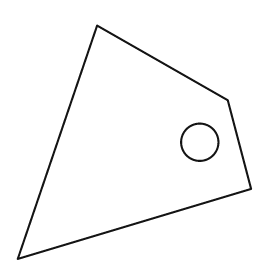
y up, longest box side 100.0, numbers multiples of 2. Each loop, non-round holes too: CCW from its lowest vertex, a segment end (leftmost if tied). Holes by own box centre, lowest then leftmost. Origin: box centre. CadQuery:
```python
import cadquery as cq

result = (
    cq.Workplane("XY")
    .moveTo(-50.0, -50.0)
    .lineTo(50.0, -20.0)
    .lineTo(40.0, 18.0)
    .lineTo(-16.0, 50.0)
    .close()
    .moveTo(28.0, 0.0)
    .circle(8.0)
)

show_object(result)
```